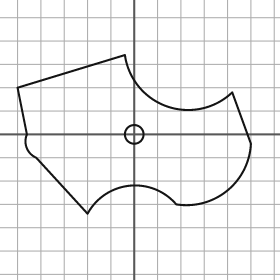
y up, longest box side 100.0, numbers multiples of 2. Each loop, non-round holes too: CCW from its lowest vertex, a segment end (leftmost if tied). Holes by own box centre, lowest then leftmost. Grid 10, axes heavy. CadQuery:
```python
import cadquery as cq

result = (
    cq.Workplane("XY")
    .moveTo(-20.0, -34.0)
    .threePointArc((-2.0, -22.0), (18.0, -30.0))
    .threePointArc((40.0, -24.0), (50.0, -4.0))
    .lineTo(42.0, 18.0)
    .threePointArc((14.0, 12.0), (-4.0, 34.0))
    .lineTo(-50.0, 20.0)
    .lineTo(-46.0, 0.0)
    .threePointArc((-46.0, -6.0), (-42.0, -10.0))
    .close()
    .moveTo(0.0, 0.0)
    .circle(4.0)
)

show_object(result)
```